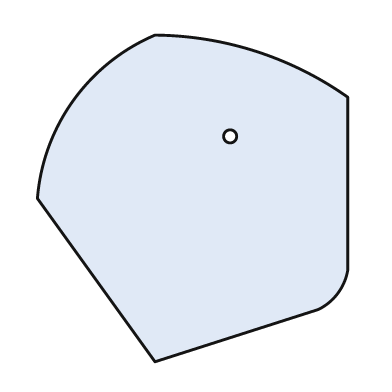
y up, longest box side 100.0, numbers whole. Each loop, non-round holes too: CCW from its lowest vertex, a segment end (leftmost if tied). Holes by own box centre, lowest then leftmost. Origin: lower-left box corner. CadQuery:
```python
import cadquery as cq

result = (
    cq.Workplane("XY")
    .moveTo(36.0, 0.0)
    .lineTo(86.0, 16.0)
    .threePointArc((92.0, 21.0), (95.0, 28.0))
    .lineTo(95.0, 81.0)
    .threePointArc((67.0, 95.0), (36.0, 100.0))
    .threePointArc((11.0, 80.0), (0.0, 50.0))
    .close()
    .moveTo(59.0, 69.0)
    .circle(2.0)
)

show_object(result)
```